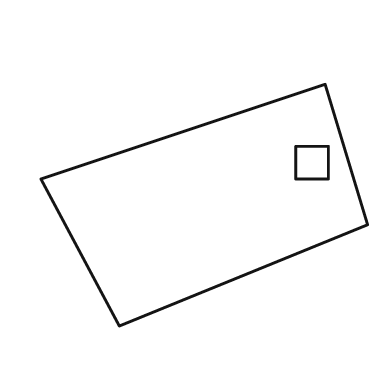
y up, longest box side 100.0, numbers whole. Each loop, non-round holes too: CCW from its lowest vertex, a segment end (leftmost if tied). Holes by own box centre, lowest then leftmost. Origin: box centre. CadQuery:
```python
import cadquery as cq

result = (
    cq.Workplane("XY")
    .moveTo(-26.0, -37.0)
    .lineTo(50.0, -6.0)
    .lineTo(37.0, 37.0)
    .lineTo(-50.0, 8.0)
    .close()
    .moveTo(28.0, 8.0)
    .lineTo(38.0, 8.0)
    .lineTo(38.0, 18.0)
    .lineTo(28.0, 18.0)
    .close()
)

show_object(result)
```